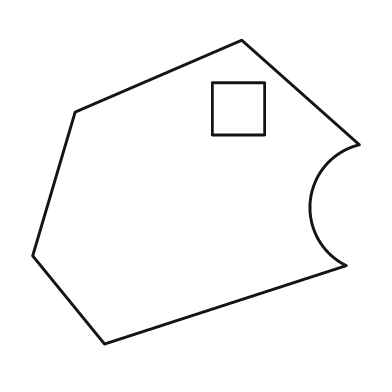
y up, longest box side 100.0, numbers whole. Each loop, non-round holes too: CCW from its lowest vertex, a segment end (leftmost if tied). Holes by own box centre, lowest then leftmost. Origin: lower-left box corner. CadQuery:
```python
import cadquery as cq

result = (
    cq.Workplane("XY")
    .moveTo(22.0, 0.0)
    .lineTo(96.0, 24.0)
    .threePointArc((85.0, 44.0), (100.0, 61.0))
    .lineTo(64.0, 93.0)
    .lineTo(13.0, 71.0)
    .lineTo(0.0, 27.0)
    .close()
    .moveTo(55.0, 64.0)
    .lineTo(71.0, 64.0)
    .lineTo(71.0, 80.0)
    .lineTo(55.0, 80.0)
    .close()
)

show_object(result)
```